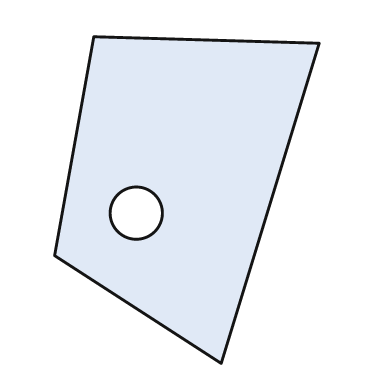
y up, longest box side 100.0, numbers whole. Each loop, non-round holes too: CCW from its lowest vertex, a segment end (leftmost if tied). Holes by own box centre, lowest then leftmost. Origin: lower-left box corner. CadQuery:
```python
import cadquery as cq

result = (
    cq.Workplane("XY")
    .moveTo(51.0, 0.0)
    .lineTo(81.0, 98.0)
    .lineTo(12.0, 100.0)
    .lineTo(0.0, 33.0)
    .close()
    .moveTo(25.0, 46.0)
    .circle(8.0)
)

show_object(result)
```